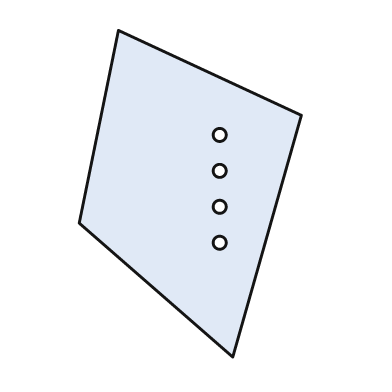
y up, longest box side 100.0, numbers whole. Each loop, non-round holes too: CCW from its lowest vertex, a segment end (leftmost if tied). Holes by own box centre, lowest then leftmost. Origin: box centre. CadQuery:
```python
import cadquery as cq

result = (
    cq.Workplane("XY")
    .moveTo(13.0, -50.0)
    .lineTo(34.0, 24.0)
    .lineTo(-22.0, 50.0)
    .lineTo(-34.0, -9.0)
    .close()
    .moveTo(9.0, -15.0)
    .circle(2.0)
    .moveTo(9.0, -4.0)
    .circle(2.0)
    .moveTo(9.0, 7.0)
    .circle(2.0)
    .moveTo(9.0, 18.0)
    .circle(2.0)
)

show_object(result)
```